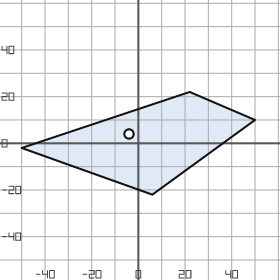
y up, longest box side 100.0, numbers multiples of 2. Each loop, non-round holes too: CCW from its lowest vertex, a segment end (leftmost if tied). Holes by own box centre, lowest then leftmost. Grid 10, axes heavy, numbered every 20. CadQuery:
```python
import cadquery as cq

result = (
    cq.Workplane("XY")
    .moveTo(6.0, -22.0)
    .lineTo(50.0, 10.0)
    .lineTo(22.0, 22.0)
    .lineTo(-50.0, -2.0)
    .close()
    .moveTo(-4.0, 4.0)
    .circle(2.0)
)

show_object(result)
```